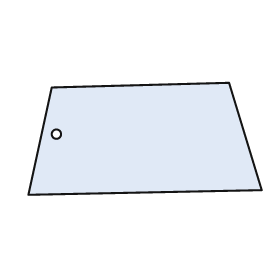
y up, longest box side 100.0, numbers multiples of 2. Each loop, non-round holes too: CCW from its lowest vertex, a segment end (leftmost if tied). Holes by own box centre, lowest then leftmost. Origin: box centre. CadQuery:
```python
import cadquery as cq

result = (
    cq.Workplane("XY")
    .moveTo(-50.0, -24.0)
    .lineTo(50.0, -22.0)
    .lineTo(36.0, 24.0)
    .lineTo(-40.0, 22.0)
    .close()
    .moveTo(-38.0, 2.0)
    .circle(2.0)
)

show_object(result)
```